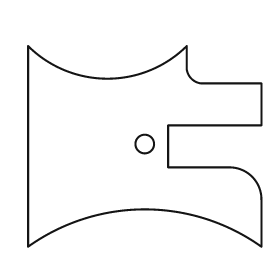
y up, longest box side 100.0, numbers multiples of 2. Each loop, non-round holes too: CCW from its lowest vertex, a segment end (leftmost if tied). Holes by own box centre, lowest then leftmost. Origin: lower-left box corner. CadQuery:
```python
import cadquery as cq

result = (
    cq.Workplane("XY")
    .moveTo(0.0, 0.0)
    .threePointArc((50.0, 16.0), (100.0, 0.0))
    .lineTo(100.0, 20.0)
    .threePointArc((96.0, 30.0), (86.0, 34.0))
    .lineTo(60.0, 34.0)
    .lineTo(60.0, 52.0)
    .lineTo(100.0, 52.0)
    .lineTo(100.0, 70.0)
    .lineTo(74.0, 70.0)
    .threePointArc((70.0, 72.0), (68.0, 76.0))
    .lineTo(68.0, 86.0)
    .threePointArc((34.0, 72.0), (0.0, 86.0))
    .close()
    .moveTo(50.0, 44.0)
    .circle(4.0)
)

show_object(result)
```